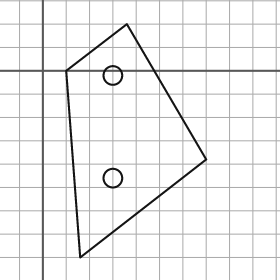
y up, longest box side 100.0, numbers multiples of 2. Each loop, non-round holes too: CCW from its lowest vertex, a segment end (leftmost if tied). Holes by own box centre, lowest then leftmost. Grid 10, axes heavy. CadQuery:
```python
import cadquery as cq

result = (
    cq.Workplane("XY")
    .moveTo(16.0, -80.0)
    .lineTo(70.0, -38.0)
    .lineTo(36.0, 20.0)
    .lineTo(10.0, 0.0)
    .close()
    .moveTo(30.0, -46.0)
    .circle(4.0)
    .moveTo(30.0, -2.0)
    .circle(4.0)
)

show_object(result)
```